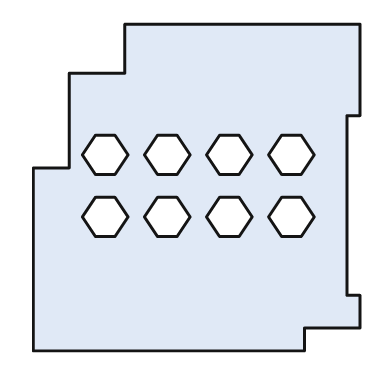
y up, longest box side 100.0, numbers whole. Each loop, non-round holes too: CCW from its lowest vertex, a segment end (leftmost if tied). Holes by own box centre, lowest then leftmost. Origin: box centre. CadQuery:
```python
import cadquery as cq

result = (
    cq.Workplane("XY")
    .moveTo(-50.0, -50.0)
    .lineTo(33.0, -50.0)
    .lineTo(33.0, -43.0)
    .lineTo(50.0, -43.0)
    .lineTo(50.0, -33.0)
    .lineTo(46.0, -33.0)
    .lineTo(46.0, 22.0)
    .lineTo(50.0, 22.0)
    .lineTo(50.0, 50.0)
    .lineTo(-22.0, 50.0)
    .lineTo(-22.0, 35.0)
    .lineTo(-39.0, 35.0)
    .lineTo(-39.0, 6.0)
    .lineTo(-50.0, 6.0)
    .close()
    .moveTo(-31.0, -15.0)
    .lineTo(-25.0, -15.0)
    .lineTo(-21.0, -9.0)
    .lineTo(-25.0, -3.0)
    .lineTo(-31.0, -3.0)
    .lineTo(-35.0, -9.0)
    .close()
    .moveTo(-12.0, -15.0)
    .lineTo(-6.0, -15.0)
    .lineTo(-2.0, -9.0)
    .lineTo(-6.0, -3.0)
    .lineTo(-12.0, -3.0)
    .lineTo(-16.0, -9.0)
    .close()
    .moveTo(7.0, -15.0)
    .lineTo(13.0, -15.0)
    .lineTo(17.0, -9.0)
    .lineTo(13.0, -3.0)
    .lineTo(7.0, -3.0)
    .lineTo(3.0, -9.0)
    .close()
    .moveTo(26.0, -15.0)
    .lineTo(32.0, -15.0)
    .lineTo(36.0, -9.0)
    .lineTo(32.0, -3.0)
    .lineTo(26.0, -3.0)
    .lineTo(22.0, -9.0)
    .close()
    .moveTo(-31.0, 4.0)
    .lineTo(-25.0, 4.0)
    .lineTo(-21.0, 10.0)
    .lineTo(-25.0, 16.0)
    .lineTo(-31.0, 16.0)
    .lineTo(-35.0, 10.0)
    .close()
    .moveTo(-12.0, 4.0)
    .lineTo(-6.0, 4.0)
    .lineTo(-2.0, 10.0)
    .lineTo(-6.0, 16.0)
    .lineTo(-12.0, 16.0)
    .lineTo(-16.0, 10.0)
    .close()
    .moveTo(7.0, 4.0)
    .lineTo(13.0, 4.0)
    .lineTo(17.0, 10.0)
    .lineTo(13.0, 16.0)
    .lineTo(7.0, 16.0)
    .lineTo(3.0, 10.0)
    .close()
    .moveTo(26.0, 4.0)
    .lineTo(32.0, 4.0)
    .lineTo(36.0, 10.0)
    .lineTo(32.0, 16.0)
    .lineTo(26.0, 16.0)
    .lineTo(22.0, 10.0)
    .close()
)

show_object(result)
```